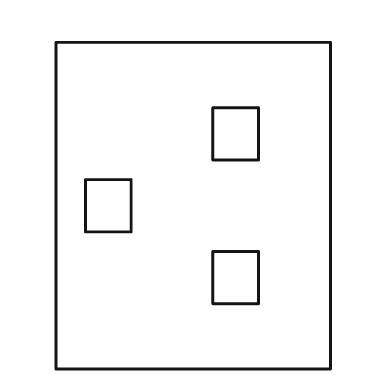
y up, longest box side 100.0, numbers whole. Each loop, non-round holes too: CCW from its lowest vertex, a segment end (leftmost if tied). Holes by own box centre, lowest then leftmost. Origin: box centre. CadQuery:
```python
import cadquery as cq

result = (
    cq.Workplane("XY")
    .moveTo(-42.0, -50.0)
    .lineTo(42.0, -50.0)
    .lineTo(42.0, 50.0)
    .lineTo(-42.0, 50.0)
    .close()
    .moveTo(6.0, -30.0)
    .lineTo(20.0, -30.0)
    .lineTo(20.0, -14.0)
    .lineTo(6.0, -14.0)
    .close()
    .moveTo(-33.0, -8.0)
    .lineTo(-19.0, -8.0)
    .lineTo(-19.0, 8.0)
    .lineTo(-33.0, 8.0)
    .close()
    .moveTo(6.0, 14.0)
    .lineTo(20.0, 14.0)
    .lineTo(20.0, 30.0)
    .lineTo(6.0, 30.0)
    .close()
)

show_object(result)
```